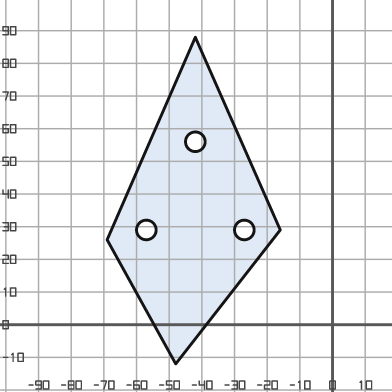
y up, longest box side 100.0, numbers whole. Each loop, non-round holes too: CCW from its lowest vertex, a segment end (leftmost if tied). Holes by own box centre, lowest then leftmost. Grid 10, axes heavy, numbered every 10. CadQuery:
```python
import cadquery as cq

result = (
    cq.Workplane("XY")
    .moveTo(-48.0, -12.0)
    .lineTo(-16.0, 29.0)
    .lineTo(-42.0, 88.0)
    .lineTo(-69.0, 26.0)
    .close()
    .moveTo(-57.0, 29.0)
    .circle(3.0)
    .moveTo(-27.0, 29.0)
    .circle(3.0)
    .moveTo(-42.0, 56.0)
    .circle(3.0)
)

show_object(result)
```